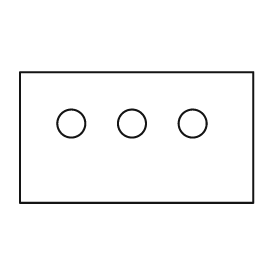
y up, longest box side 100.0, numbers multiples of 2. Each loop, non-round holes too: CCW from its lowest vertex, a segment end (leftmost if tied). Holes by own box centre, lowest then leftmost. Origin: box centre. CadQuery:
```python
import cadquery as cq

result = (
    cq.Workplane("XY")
    .moveTo(-50.0, -28.0)
    .lineTo(50.0, -28.0)
    .lineTo(50.0, 28.0)
    .lineTo(-50.0, 28.0)
    .close()
    .moveTo(-28.0, 6.0)
    .circle(6.0)
    .moveTo(-2.0, 6.0)
    .circle(6.0)
    .moveTo(24.0, 6.0)
    .circle(6.0)
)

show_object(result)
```